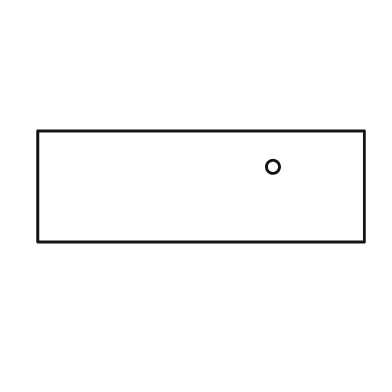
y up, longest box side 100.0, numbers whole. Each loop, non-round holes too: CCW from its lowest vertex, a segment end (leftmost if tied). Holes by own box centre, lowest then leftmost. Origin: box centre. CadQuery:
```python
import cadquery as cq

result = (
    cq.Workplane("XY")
    .moveTo(-50.0, -17.0)
    .lineTo(50.0, -17.0)
    .lineTo(50.0, 17.0)
    .lineTo(-50.0, 17.0)
    .close()
    .moveTo(22.0, 6.0)
    .circle(2.0)
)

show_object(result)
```